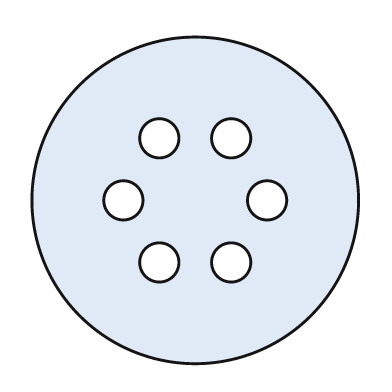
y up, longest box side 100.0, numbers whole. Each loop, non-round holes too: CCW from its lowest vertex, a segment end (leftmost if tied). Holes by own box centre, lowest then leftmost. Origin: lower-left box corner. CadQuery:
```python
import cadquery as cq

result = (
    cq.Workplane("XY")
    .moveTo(50.0, 50.0)
    .circle(50.0)
    .moveTo(39.0, 31.0)
    .circle(6.0)
    .moveTo(61.0, 31.0)
    .circle(6.0)
    .moveTo(28.0, 50.0)
    .circle(6.0)
    .moveTo(72.0, 50.0)
    .circle(6.0)
    .moveTo(39.0, 69.0)
    .circle(6.0)
    .moveTo(61.0, 69.0)
    .circle(6.0)
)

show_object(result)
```